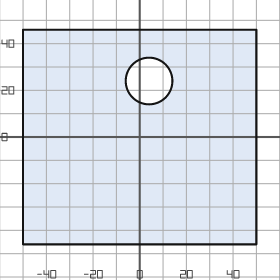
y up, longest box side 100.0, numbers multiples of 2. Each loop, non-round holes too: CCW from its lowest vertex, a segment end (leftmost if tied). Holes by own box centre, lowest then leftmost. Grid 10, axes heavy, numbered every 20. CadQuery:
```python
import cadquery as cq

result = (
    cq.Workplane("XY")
    .moveTo(-50.0, -46.0)
    .lineTo(50.0, -46.0)
    .lineTo(50.0, 46.0)
    .lineTo(-50.0, 46.0)
    .close()
    .moveTo(4.0, 24.0)
    .circle(10.0)
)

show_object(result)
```